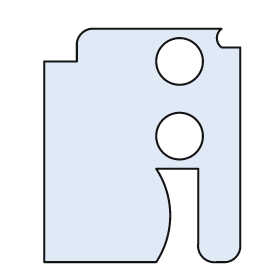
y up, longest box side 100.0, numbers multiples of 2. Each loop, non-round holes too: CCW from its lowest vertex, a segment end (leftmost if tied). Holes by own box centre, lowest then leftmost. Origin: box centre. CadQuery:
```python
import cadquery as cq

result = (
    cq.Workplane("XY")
    .moveTo(-42.0, -50.0)
    .lineTo(6.0, -50.0)
    .threePointArc((12.0, -30.0), (6.0, -10.0))
    .lineTo(24.0, -10.0)
    .lineTo(24.0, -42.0)
    .threePointArc((26.0, -48.0), (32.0, -50.0))
    .lineTo(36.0, -50.0)
    .threePointArc((40.0, -48.0), (42.0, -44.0))
    .lineTo(42.0, 42.0)
    .lineTo(34.0, 42.0)
    .threePointArc((32.0, 46.0), (34.0, 50.0))
    .lineTo(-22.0, 50.0)
    .threePointArc((-26.0, 48.0), (-28.0, 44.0))
    .lineTo(-28.0, 36.0)
    .lineTo(-42.0, 36.0)
    .close()
    .moveTo(16.0, 4.0)
    .circle(10.0)
    .moveTo(16.0, 36.0)
    .circle(10.0)
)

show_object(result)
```